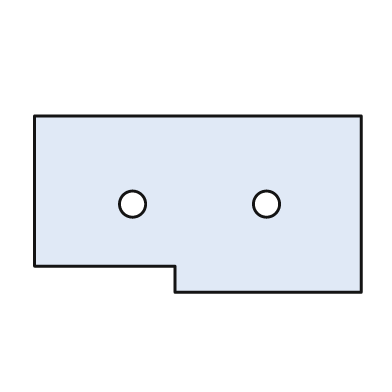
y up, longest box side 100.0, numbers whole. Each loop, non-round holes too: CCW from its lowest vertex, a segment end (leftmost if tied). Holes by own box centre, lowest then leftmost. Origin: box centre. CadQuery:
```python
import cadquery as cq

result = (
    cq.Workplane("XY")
    .moveTo(-7.0, -27.0)
    .lineTo(50.0, -27.0)
    .lineTo(50.0, 27.0)
    .lineTo(-50.0, 27.0)
    .lineTo(-50.0, -19.0)
    .lineTo(-7.0, -19.0)
    .close()
    .moveTo(-20.0, 0.0)
    .circle(4.0)
    .moveTo(21.0, 0.0)
    .circle(4.0)
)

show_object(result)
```